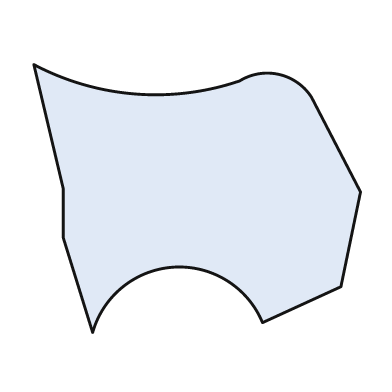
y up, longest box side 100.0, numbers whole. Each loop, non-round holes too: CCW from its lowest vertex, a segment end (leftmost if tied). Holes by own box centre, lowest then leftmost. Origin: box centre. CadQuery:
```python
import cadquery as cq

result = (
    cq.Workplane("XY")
    .moveTo(-32.0, -41.0)
    .threePointArc((-7.0, -21.0), (20.0, -38.0))
    .lineTo(44.0, -27.0)
    .lineTo(50.0, 2.0)
    .lineTo(35.0, 31.0)
    .threePointArc((25.0, 38.0), (13.0, 36.0))
    .threePointArc((-19.0, 32.0), (-50.0, 41.0))
    .lineTo(-41.0, 3.0)
    .lineTo(-41.0, -12.0)
    .close()
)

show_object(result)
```